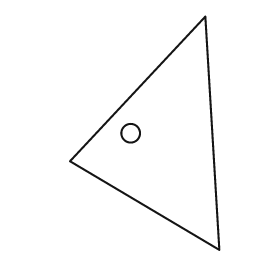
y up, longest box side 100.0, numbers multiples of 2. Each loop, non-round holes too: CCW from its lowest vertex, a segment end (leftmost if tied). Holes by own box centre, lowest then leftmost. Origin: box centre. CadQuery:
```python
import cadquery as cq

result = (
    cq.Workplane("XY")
    .moveTo(32.0, -50.0)
    .lineTo(26.0, 50.0)
    .lineTo(-32.0, -12.0)
    .close()
    .moveTo(-6.0, 0.0)
    .circle(4.0)
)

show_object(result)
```